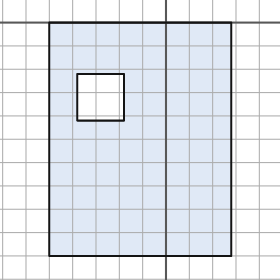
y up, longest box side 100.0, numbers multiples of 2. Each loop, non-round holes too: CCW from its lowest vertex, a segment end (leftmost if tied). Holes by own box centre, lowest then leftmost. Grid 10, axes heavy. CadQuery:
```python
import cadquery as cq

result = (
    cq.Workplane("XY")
    .moveTo(-50.0, -100.0)
    .lineTo(28.0, -100.0)
    .lineTo(28.0, 0.0)
    .lineTo(-50.0, 0.0)
    .close()
    .moveTo(-38.0, -42.0)
    .lineTo(-18.0, -42.0)
    .lineTo(-18.0, -22.0)
    .lineTo(-38.0, -22.0)
    .close()
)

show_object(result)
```